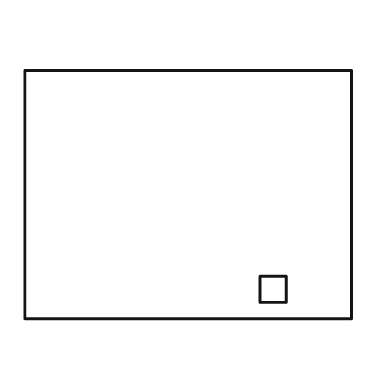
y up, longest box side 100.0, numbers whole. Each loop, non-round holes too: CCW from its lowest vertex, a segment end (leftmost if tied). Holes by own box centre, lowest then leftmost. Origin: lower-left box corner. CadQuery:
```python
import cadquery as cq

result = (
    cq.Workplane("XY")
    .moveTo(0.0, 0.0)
    .lineTo(100.0, 0.0)
    .lineTo(100.0, 76.0)
    .lineTo(0.0, 76.0)
    .close()
    .moveTo(72.0, 5.0)
    .lineTo(80.0, 5.0)
    .lineTo(80.0, 13.0)
    .lineTo(72.0, 13.0)
    .close()
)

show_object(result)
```